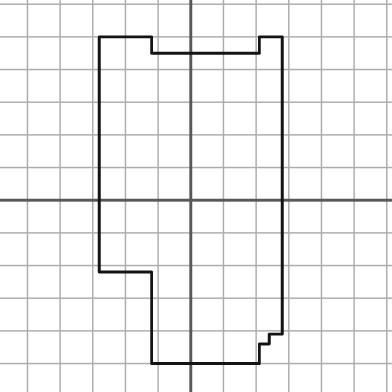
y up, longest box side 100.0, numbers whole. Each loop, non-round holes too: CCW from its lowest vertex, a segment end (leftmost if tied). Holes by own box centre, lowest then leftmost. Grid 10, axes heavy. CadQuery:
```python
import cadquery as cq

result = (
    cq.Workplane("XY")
    .moveTo(-12.0, -50.0)
    .lineTo(21.0, -50.0)
    .lineTo(21.0, -44.0)
    .lineTo(24.0, -44.0)
    .lineTo(24.0, -41.0)
    .lineTo(28.0, -41.0)
    .lineTo(28.0, 50.0)
    .lineTo(21.0, 50.0)
    .lineTo(21.0, 45.0)
    .lineTo(-12.0, 45.0)
    .lineTo(-12.0, 50.0)
    .lineTo(-28.0, 50.0)
    .lineTo(-28.0, -22.0)
    .lineTo(-12.0, -22.0)
    .close()
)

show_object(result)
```